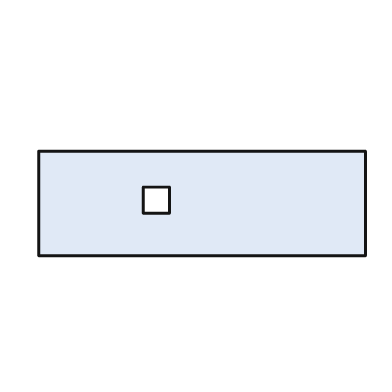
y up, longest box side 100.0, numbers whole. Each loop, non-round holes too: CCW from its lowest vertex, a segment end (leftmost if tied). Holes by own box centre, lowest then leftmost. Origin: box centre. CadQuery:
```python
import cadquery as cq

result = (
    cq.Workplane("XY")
    .moveTo(-50.0, -16.0)
    .lineTo(50.0, -16.0)
    .lineTo(50.0, 16.0)
    .lineTo(-50.0, 16.0)
    .close()
    .moveTo(-18.0, -3.0)
    .lineTo(-10.0, -3.0)
    .lineTo(-10.0, 5.0)
    .lineTo(-18.0, 5.0)
    .close()
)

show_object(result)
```